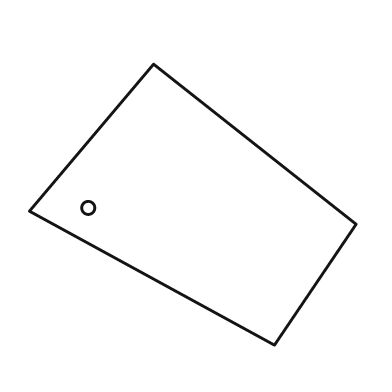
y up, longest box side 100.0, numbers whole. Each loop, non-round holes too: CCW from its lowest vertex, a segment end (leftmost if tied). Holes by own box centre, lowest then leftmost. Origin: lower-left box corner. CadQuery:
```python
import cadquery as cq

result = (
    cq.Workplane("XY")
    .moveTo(75.0, 0.0)
    .lineTo(100.0, 37.0)
    .lineTo(38.0, 86.0)
    .lineTo(0.0, 41.0)
    .close()
    .moveTo(18.0, 42.0)
    .circle(2.0)
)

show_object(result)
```